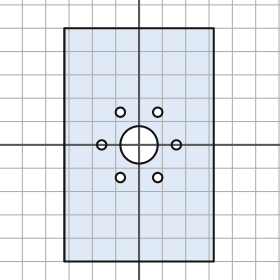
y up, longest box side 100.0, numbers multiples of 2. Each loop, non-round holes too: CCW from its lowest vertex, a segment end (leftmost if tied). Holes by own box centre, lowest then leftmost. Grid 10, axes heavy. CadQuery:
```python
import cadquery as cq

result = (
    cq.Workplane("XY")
    .moveTo(-32.0, -50.0)
    .lineTo(32.0, -50.0)
    .lineTo(32.0, 50.0)
    .lineTo(-32.0, 50.0)
    .close()
    .moveTo(-8.0, -14.0)
    .circle(2.0)
    .moveTo(8.0, -14.0)
    .circle(2.0)
    .moveTo(-16.0, 0.0)
    .circle(2.0)
    .moveTo(0.0, 0.0)
    .circle(8.0)
    .moveTo(16.0, 0.0)
    .circle(2.0)
    .moveTo(-8.0, 14.0)
    .circle(2.0)
    .moveTo(8.0, 14.0)
    .circle(2.0)
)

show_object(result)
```